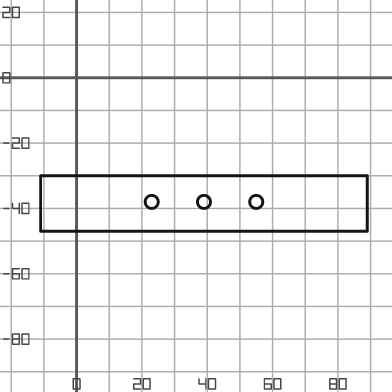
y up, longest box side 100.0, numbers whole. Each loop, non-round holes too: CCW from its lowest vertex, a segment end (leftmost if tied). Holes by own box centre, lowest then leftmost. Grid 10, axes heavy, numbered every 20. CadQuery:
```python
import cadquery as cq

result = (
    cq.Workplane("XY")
    .moveTo(-11.0, -47.0)
    .lineTo(89.0, -47.0)
    .lineTo(89.0, -30.0)
    .lineTo(-11.0, -30.0)
    .close()
    .moveTo(23.0, -38.0)
    .circle(2.0)
    .moveTo(39.0, -38.0)
    .circle(2.0)
    .moveTo(55.0, -38.0)
    .circle(2.0)
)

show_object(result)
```